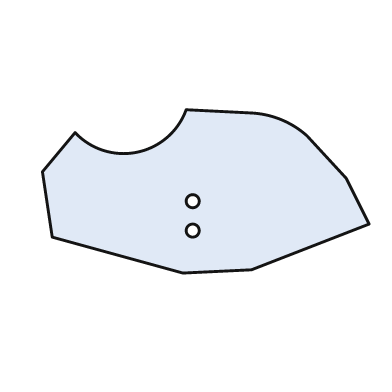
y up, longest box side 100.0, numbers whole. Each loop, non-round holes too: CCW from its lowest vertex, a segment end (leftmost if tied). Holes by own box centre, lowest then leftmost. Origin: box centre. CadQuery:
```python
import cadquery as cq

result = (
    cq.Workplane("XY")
    .moveTo(-7.0, -25.0)
    .lineTo(14.0, -24.0)
    .lineTo(50.0, -10.0)
    .lineTo(43.0, 4.0)
    .lineTo(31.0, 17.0)
    .threePointArc((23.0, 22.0), (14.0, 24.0))
    .lineTo(-6.0, 25.0)
    .threePointArc((-21.0, 12.0), (-40.0, 18.0))
    .lineTo(-50.0, 6.0)
    .lineTo(-47.0, -14.0)
    .close()
    .moveTo(-4.0, -12.0)
    .circle(2.0)
    .moveTo(-4.0, -3.0)
    .circle(2.0)
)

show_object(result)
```